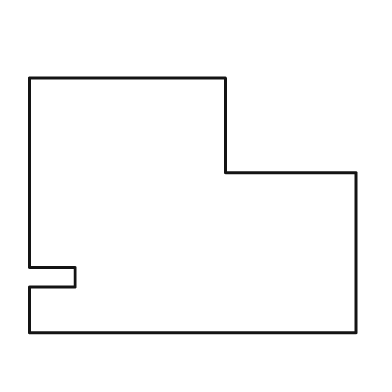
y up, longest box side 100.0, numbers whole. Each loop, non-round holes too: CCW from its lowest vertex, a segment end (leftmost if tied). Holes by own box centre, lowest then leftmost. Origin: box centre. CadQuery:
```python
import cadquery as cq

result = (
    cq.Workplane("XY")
    .moveTo(-50.0, -39.0)
    .lineTo(50.0, -39.0)
    .lineTo(50.0, 10.0)
    .lineTo(10.0, 10.0)
    .lineTo(10.0, 39.0)
    .lineTo(-50.0, 39.0)
    .lineTo(-50.0, -19.0)
    .lineTo(-36.0, -19.0)
    .lineTo(-36.0, -25.0)
    .lineTo(-50.0, -25.0)
    .close()
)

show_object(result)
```